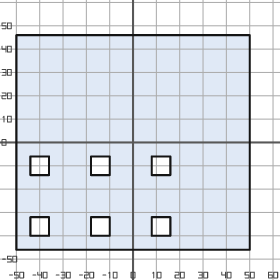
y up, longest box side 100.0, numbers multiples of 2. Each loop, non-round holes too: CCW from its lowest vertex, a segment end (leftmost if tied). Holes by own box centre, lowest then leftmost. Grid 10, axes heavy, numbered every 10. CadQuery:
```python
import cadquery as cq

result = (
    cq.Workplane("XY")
    .moveTo(-50.0, -46.0)
    .lineTo(50.0, -46.0)
    .lineTo(50.0, 46.0)
    .lineTo(-50.0, 46.0)
    .close()
    .moveTo(-44.0, -40.0)
    .lineTo(-36.0, -40.0)
    .lineTo(-36.0, -32.0)
    .lineTo(-44.0, -32.0)
    .close()
    .moveTo(-18.0, -40.0)
    .lineTo(-10.0, -40.0)
    .lineTo(-10.0, -32.0)
    .lineTo(-18.0, -32.0)
    .close()
    .moveTo(8.0, -40.0)
    .lineTo(16.0, -40.0)
    .lineTo(16.0, -32.0)
    .lineTo(8.0, -32.0)
    .close()
    .moveTo(-44.0, -14.0)
    .lineTo(-36.0, -14.0)
    .lineTo(-36.0, -6.0)
    .lineTo(-44.0, -6.0)
    .close()
    .moveTo(-18.0, -14.0)
    .lineTo(-10.0, -14.0)
    .lineTo(-10.0, -6.0)
    .lineTo(-18.0, -6.0)
    .close()
    .moveTo(8.0, -14.0)
    .lineTo(16.0, -14.0)
    .lineTo(16.0, -6.0)
    .lineTo(8.0, -6.0)
    .close()
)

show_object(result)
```